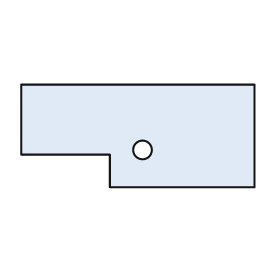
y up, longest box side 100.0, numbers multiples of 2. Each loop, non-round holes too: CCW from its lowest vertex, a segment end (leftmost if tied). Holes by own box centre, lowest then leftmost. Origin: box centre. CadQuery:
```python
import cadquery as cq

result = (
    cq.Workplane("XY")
    .moveTo(-12.0, -22.0)
    .lineTo(50.0, -22.0)
    .lineTo(50.0, 22.0)
    .lineTo(-50.0, 22.0)
    .lineTo(-50.0, -8.0)
    .lineTo(-12.0, -8.0)
    .close()
    .moveTo(2.0, -6.0)
    .circle(4.0)
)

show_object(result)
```